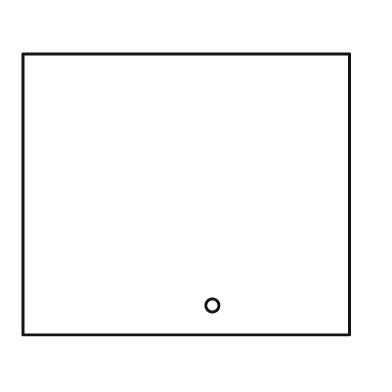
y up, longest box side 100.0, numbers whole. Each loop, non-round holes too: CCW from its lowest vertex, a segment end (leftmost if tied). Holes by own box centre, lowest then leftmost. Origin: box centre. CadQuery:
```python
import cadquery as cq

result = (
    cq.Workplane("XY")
    .moveTo(-50.0, -43.0)
    .lineTo(50.0, -43.0)
    .lineTo(50.0, 43.0)
    .lineTo(-50.0, 43.0)
    .close()
    .moveTo(8.0, -34.0)
    .circle(2.0)
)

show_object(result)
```